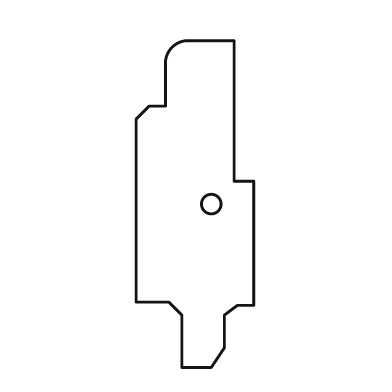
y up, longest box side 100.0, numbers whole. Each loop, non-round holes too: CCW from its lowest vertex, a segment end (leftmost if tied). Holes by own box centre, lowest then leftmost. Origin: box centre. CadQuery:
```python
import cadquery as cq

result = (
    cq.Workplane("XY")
    .moveTo(-4.0, -50.0)
    .lineTo(5.0, -50.0)
    .lineTo(9.0, -44.0)
    .lineTo(9.0, -34.0)
    .lineTo(13.0, -31.0)
    .lineTo(18.0, -31.0)
    .lineTo(18.0, 7.0)
    .lineTo(12.0, 7.0)
    .lineTo(12.0, 50.0)
    .lineTo(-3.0, 50.0)
    .threePointArc((-7.0, 48.0), (-9.0, 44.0))
    .lineTo(-9.0, 30.0)
    .lineTo(-14.0, 30.0)
    .lineTo(-18.0, 26.0)
    .lineTo(-18.0, -30.0)
    .lineTo(-8.0, -30.0)
    .lineTo(-4.0, -34.0)
    .close()
    .moveTo(5.0, 0.0)
    .circle(3.0)
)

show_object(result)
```